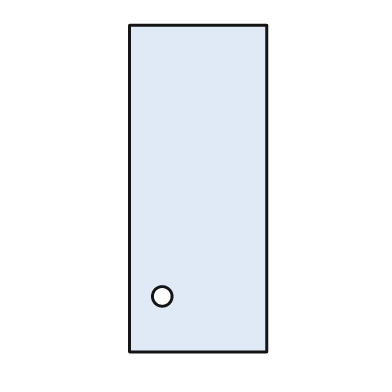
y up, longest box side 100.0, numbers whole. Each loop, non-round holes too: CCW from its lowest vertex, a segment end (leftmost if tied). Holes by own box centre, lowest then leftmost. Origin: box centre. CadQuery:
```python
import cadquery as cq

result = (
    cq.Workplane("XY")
    .moveTo(-21.0, -50.0)
    .lineTo(21.0, -50.0)
    .lineTo(21.0, 50.0)
    .lineTo(-21.0, 50.0)
    .close()
    .moveTo(-11.0, -33.0)
    .circle(3.0)
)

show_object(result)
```